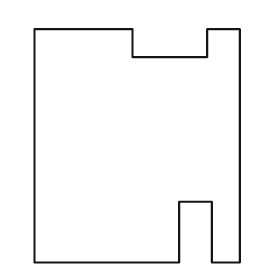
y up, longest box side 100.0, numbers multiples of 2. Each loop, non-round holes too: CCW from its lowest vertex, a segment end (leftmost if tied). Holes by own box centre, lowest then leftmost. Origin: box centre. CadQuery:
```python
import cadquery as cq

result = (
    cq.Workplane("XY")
    .moveTo(-44.0, -50.0)
    .lineTo(18.0, -50.0)
    .lineTo(18.0, -24.0)
    .lineTo(32.0, -24.0)
    .lineTo(32.0, -50.0)
    .lineTo(44.0, -50.0)
    .lineTo(44.0, 50.0)
    .lineTo(30.0, 50.0)
    .lineTo(30.0, 38.0)
    .lineTo(-2.0, 38.0)
    .lineTo(-2.0, 50.0)
    .lineTo(-44.0, 50.0)
    .close()
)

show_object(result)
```